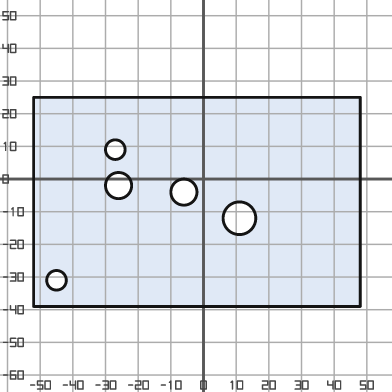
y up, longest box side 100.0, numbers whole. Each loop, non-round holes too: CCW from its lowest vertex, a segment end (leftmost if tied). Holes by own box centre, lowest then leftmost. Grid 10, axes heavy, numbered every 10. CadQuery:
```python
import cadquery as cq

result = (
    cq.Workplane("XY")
    .moveTo(-52.0, -39.0)
    .lineTo(48.0, -39.0)
    .lineTo(48.0, 25.0)
    .lineTo(-52.0, 25.0)
    .close()
    .moveTo(-45.0, -31.0)
    .circle(3.0)
    .moveTo(11.0, -12.0)
    .circle(5.0)
    .moveTo(-6.0, -4.0)
    .circle(4.0)
    .moveTo(-26.0, -2.0)
    .circle(4.0)
    .moveTo(-27.0, 9.0)
    .circle(3.0)
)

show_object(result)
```